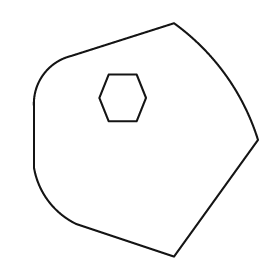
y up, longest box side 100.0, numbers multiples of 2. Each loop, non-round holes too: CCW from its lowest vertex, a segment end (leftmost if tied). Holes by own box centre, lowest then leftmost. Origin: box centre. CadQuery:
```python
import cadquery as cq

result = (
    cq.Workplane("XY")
    .moveTo(12.0, -50.0)
    .lineTo(48.0, 0.0)
    .threePointArc((34.0, 28.0), (12.0, 50.0))
    .lineTo(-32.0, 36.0)
    .threePointArc((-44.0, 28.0), (-48.0, 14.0))
    .lineTo(-48.0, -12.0)
    .threePointArc((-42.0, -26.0), (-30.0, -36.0))
    .close()
    .moveTo(-16.0, 8.0)
    .lineTo(-4.0, 8.0)
    .lineTo(0.0, 18.0)
    .lineTo(-4.0, 28.0)
    .lineTo(-16.0, 28.0)
    .lineTo(-20.0, 18.0)
    .close()
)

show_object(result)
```